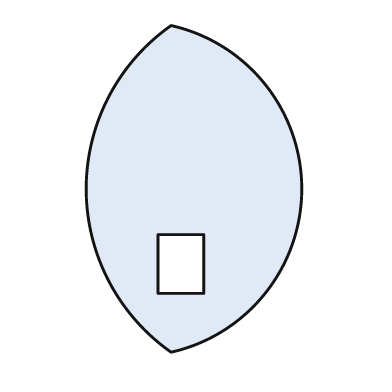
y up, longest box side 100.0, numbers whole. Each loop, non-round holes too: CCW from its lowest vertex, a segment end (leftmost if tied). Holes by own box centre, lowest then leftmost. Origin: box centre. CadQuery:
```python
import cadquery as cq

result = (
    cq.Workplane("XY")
    .moveTo(-7.0, -50.0)
    .threePointArc((33.0, 0.0), (-7.0, 50.0))
    .threePointArc((-33.0, 0.0), (-7.0, -50.0))
    .close()
    .moveTo(-11.0, -32.0)
    .lineTo(3.0, -32.0)
    .lineTo(3.0, -14.0)
    .lineTo(-11.0, -14.0)
    .close()
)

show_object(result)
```